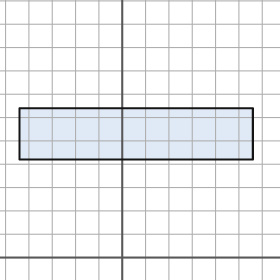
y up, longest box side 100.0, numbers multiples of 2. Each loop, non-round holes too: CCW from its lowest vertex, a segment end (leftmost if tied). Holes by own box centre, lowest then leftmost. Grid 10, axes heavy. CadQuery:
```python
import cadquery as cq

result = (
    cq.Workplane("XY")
    .moveTo(-44.0, 42.0)
    .lineTo(56.0, 42.0)
    .lineTo(56.0, 64.0)
    .lineTo(-44.0, 64.0)
    .close()
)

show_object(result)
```